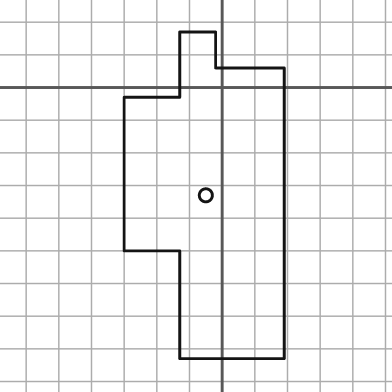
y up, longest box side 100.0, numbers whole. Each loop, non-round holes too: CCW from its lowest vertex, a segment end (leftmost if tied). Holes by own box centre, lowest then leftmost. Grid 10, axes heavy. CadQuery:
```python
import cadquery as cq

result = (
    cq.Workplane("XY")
    .moveTo(-13.0, -83.0)
    .lineTo(19.0, -83.0)
    .lineTo(19.0, 6.0)
    .lineTo(-2.0, 6.0)
    .lineTo(-2.0, 17.0)
    .lineTo(-13.0, 17.0)
    .lineTo(-13.0, -3.0)
    .lineTo(-30.0, -3.0)
    .lineTo(-30.0, -50.0)
    .lineTo(-13.0, -50.0)
    .close()
    .moveTo(-5.0, -33.0)
    .circle(2.0)
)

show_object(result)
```